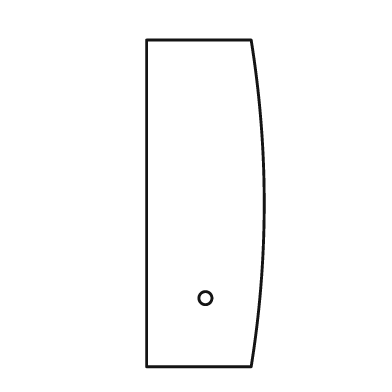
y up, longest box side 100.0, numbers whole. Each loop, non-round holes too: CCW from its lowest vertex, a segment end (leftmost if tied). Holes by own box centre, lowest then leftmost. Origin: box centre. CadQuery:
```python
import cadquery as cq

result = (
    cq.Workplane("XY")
    .moveTo(-18.0, -50.0)
    .lineTo(14.0, -50.0)
    .threePointArc((18.0, 0.0), (14.0, 50.0))
    .lineTo(-18.0, 50.0)
    .close()
    .moveTo(0.0, -29.0)
    .circle(2.0)
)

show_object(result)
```